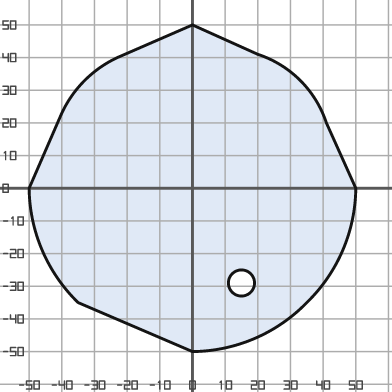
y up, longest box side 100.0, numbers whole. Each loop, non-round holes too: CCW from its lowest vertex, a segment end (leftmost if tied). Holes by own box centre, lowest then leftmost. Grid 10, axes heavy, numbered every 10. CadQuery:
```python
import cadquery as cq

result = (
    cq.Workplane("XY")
    .moveTo(0.0, -50.0)
    .threePointArc((19.0, -46.0), (35.0, -35.0))
    .threePointArc((46.0, -19.0), (50.0, 0.0))
    .lineTo(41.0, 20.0)
    .threePointArc((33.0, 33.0), (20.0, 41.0))
    .lineTo(0.0, 50.0)
    .lineTo(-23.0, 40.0)
    .threePointArc((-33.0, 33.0), (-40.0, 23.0))
    .lineTo(-50.0, 0.0)
    .threePointArc((-46.0, -19.0), (-35.0, -35.0))
    .close()
    .moveTo(15.0, -29.0)
    .circle(4.0)
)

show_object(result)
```